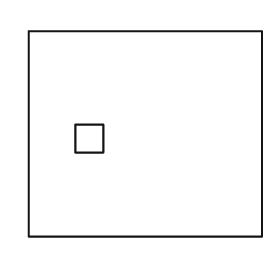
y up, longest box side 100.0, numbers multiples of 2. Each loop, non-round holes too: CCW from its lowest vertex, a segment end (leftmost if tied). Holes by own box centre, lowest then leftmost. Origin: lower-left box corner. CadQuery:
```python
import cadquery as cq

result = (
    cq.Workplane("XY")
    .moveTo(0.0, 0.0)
    .lineTo(100.0, 0.0)
    .lineTo(100.0, 88.0)
    .lineTo(0.0, 88.0)
    .close()
    .moveTo(20.0, 36.0)
    .lineTo(32.0, 36.0)
    .lineTo(32.0, 48.0)
    .lineTo(20.0, 48.0)
    .close()
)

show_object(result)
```